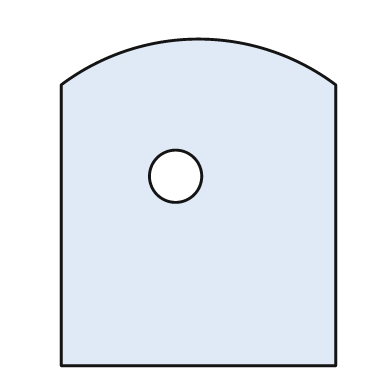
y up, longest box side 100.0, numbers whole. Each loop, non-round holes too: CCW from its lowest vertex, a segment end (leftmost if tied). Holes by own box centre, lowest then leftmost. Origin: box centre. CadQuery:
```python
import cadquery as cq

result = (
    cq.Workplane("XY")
    .moveTo(-42.0, -50.0)
    .lineTo(42.0, -50.0)
    .lineTo(42.0, 36.0)
    .threePointArc((0.0, 50.0), (-42.0, 36.0))
    .close()
    .moveTo(-7.0, 8.0)
    .circle(8.0)
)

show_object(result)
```